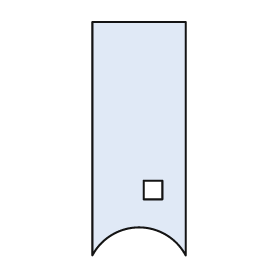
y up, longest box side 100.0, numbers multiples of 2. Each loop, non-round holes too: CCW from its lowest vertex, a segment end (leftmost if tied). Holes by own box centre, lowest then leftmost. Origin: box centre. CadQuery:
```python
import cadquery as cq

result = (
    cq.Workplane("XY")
    .moveTo(-20.0, -50.0)
    .threePointArc((0.0, -38.0), (20.0, -50.0))
    .lineTo(20.0, 50.0)
    .lineTo(-20.0, 50.0)
    .close()
    .moveTo(2.0, -26.0)
    .lineTo(10.0, -26.0)
    .lineTo(10.0, -18.0)
    .lineTo(2.0, -18.0)
    .close()
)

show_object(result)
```